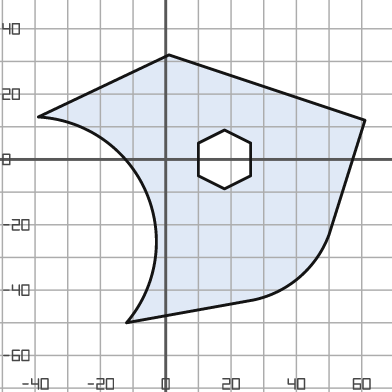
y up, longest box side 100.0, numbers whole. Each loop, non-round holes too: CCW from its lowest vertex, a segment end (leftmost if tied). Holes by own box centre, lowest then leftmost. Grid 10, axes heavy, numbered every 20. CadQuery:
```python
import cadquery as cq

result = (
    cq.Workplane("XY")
    .moveTo(-12.0, -50.0)
    .lineTo(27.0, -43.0)
    .threePointArc((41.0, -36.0), (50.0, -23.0))
    .lineTo(61.0, 12.0)
    .lineTo(1.0, 32.0)
    .lineTo(-39.0, 13.0)
    .threePointArc((-6.0, -10.0), (-12.0, -50.0))
    .close()
    .moveTo(18.0, -9.0)
    .lineTo(26.0, -5.0)
    .lineTo(26.0, 5.0)
    .lineTo(18.0, 9.0)
    .lineTo(10.0, 5.0)
    .lineTo(10.0, -5.0)
    .close()
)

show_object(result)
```